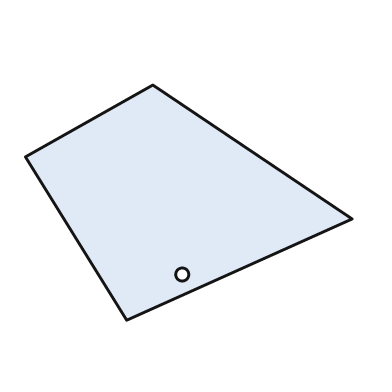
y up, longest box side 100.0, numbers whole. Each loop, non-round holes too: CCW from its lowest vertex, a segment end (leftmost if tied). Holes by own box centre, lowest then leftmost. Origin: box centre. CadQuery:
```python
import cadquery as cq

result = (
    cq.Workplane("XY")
    .moveTo(-19.0, -36.0)
    .lineTo(50.0, -5.0)
    .lineTo(-11.0, 36.0)
    .lineTo(-50.0, 14.0)
    .close()
    .moveTo(-2.0, -22.0)
    .circle(2.0)
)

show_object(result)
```